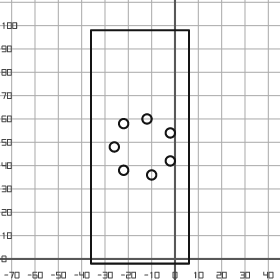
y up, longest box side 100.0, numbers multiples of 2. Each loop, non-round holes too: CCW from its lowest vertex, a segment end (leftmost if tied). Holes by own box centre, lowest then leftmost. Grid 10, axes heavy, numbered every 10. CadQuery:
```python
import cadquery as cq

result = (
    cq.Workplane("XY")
    .moveTo(-36.0, -2.0)
    .lineTo(6.0, -2.0)
    .lineTo(6.0, 98.0)
    .lineTo(-36.0, 98.0)
    .close()
    .moveTo(-10.0, 36.0)
    .circle(2.0)
    .moveTo(-22.0, 38.0)
    .circle(2.0)
    .moveTo(-2.0, 42.0)
    .circle(2.0)
    .moveTo(-26.0, 48.0)
    .circle(2.0)
    .moveTo(-2.0, 54.0)
    .circle(2.0)
    .moveTo(-22.0, 58.0)
    .circle(2.0)
    .moveTo(-12.0, 60.0)
    .circle(2.0)
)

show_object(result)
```